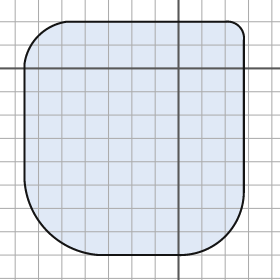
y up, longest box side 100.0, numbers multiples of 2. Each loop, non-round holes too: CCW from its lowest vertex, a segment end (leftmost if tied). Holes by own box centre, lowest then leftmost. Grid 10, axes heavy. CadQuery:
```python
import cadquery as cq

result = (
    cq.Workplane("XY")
    .moveTo(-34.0, -80.0)
    .lineTo(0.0, -80.0)
    .threePointArc((20.0, -72.0), (28.0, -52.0))
    .lineTo(28.0, 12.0)
    .threePointArc((26.0, 18.0), (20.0, 20.0))
    .lineTo(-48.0, 20.0)
    .threePointArc((-60.0, 14.0), (-66.0, 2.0))
    .lineTo(-66.0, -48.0)
    .threePointArc((-56.0, -70.0), (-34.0, -80.0))
    .close()
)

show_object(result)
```